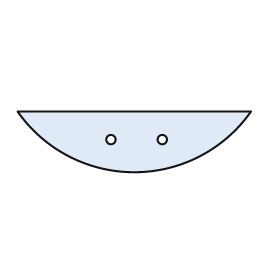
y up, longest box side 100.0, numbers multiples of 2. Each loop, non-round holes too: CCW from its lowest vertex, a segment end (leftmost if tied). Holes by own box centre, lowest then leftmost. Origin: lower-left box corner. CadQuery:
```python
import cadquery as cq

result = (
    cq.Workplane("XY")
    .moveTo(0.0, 26.0)
    .threePointArc((50.0, 0.0), (100.0, 26.0))
    .close()
    .moveTo(40.0, 14.0)
    .circle(2.0)
    .moveTo(62.0, 14.0)
    .circle(2.0)
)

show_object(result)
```